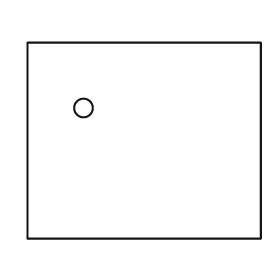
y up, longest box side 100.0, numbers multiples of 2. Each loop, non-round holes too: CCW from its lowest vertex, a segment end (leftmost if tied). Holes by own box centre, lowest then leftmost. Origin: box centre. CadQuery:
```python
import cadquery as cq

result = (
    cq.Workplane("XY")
    .moveTo(-50.0, -42.0)
    .lineTo(50.0, -42.0)
    .lineTo(50.0, 42.0)
    .lineTo(-50.0, 42.0)
    .close()
    .moveTo(-26.0, 14.0)
    .circle(4.0)
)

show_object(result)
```